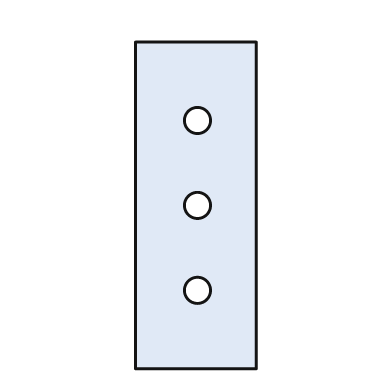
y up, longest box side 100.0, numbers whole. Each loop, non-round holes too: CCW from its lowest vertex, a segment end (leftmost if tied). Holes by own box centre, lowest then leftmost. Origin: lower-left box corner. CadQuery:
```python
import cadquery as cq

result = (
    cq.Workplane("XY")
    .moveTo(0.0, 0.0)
    .lineTo(37.0, 0.0)
    .lineTo(37.0, 100.0)
    .lineTo(0.0, 100.0)
    .close()
    .moveTo(19.0, 24.0)
    .circle(4.0)
    .moveTo(19.0, 50.0)
    .circle(4.0)
    .moveTo(19.0, 76.0)
    .circle(4.0)
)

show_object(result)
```